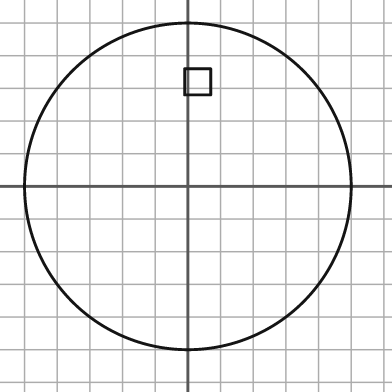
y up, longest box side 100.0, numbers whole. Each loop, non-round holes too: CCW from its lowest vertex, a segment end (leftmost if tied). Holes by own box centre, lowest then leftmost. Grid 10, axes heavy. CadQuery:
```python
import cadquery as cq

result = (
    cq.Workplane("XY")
    .moveTo(0.0, 0.0)
    .circle(50.0)
    .moveTo(-1.0, 28.0)
    .lineTo(7.0, 28.0)
    .lineTo(7.0, 36.0)
    .lineTo(-1.0, 36.0)
    .close()
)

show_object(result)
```